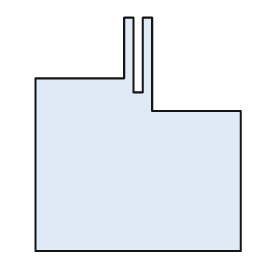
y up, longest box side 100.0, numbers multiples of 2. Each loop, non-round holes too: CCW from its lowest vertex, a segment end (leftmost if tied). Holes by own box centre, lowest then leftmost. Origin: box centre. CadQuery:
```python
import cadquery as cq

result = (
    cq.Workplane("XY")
    .moveTo(-44.0, -50.0)
    .lineTo(44.0, -50.0)
    .lineTo(44.0, 10.0)
    .lineTo(6.0, 10.0)
    .lineTo(6.0, 50.0)
    .lineTo(2.0, 50.0)
    .lineTo(2.0, 18.0)
    .lineTo(-2.0, 18.0)
    .lineTo(-2.0, 50.0)
    .lineTo(-6.0, 50.0)
    .lineTo(-6.0, 24.0)
    .lineTo(-44.0, 24.0)
    .close()
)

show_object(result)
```